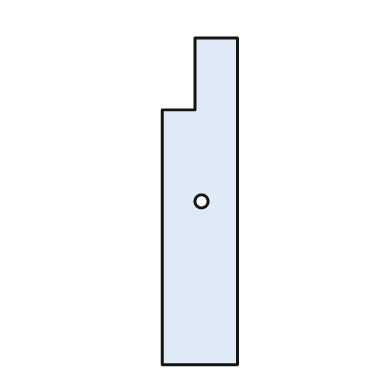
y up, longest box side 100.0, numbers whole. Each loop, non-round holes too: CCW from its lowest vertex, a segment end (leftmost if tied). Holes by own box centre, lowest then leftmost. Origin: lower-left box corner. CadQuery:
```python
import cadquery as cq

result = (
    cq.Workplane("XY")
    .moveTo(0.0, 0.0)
    .lineTo(23.0, 0.0)
    .lineTo(23.0, 100.0)
    .lineTo(10.0, 100.0)
    .lineTo(10.0, 78.0)
    .lineTo(0.0, 78.0)
    .close()
    .moveTo(12.0, 50.0)
    .circle(2.0)
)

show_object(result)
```